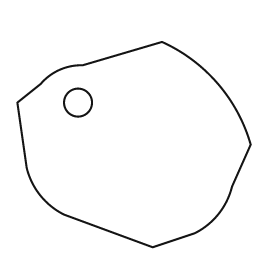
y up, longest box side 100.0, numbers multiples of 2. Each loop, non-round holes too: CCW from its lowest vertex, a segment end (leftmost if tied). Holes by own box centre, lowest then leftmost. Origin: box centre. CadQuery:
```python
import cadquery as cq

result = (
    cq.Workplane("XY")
    .moveTo(8.0, -44.0)
    .lineTo(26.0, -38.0)
    .threePointArc((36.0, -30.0), (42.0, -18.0))
    .lineTo(50.0, 0.0)
    .threePointArc((36.0, 26.0), (12.0, 44.0))
    .lineTo(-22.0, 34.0)
    .threePointArc((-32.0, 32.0), (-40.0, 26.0))
    .lineTo(-50.0, 18.0)
    .lineTo(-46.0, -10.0)
    .threePointArc((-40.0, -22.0), (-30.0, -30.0))
    .close()
    .moveTo(-24.0, 18.0)
    .circle(6.0)
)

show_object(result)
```